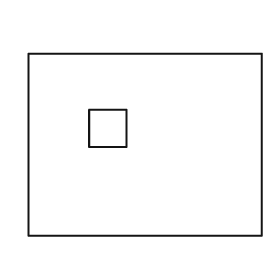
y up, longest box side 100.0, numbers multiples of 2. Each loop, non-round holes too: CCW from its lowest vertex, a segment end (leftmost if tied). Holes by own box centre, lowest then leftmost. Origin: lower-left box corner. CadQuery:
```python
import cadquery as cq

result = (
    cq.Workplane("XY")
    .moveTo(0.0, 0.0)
    .lineTo(100.0, 0.0)
    .lineTo(100.0, 78.0)
    .lineTo(0.0, 78.0)
    .close()
    .moveTo(26.0, 38.0)
    .lineTo(42.0, 38.0)
    .lineTo(42.0, 54.0)
    .lineTo(26.0, 54.0)
    .close()
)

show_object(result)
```